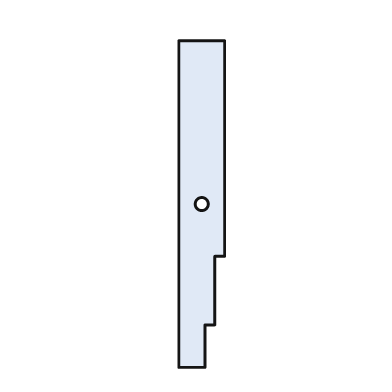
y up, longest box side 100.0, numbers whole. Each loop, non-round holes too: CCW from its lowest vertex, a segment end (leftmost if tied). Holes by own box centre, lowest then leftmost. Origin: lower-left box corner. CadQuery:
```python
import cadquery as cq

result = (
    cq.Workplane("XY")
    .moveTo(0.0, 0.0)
    .lineTo(8.0, 0.0)
    .lineTo(8.0, 13.0)
    .lineTo(11.0, 13.0)
    .lineTo(11.0, 34.0)
    .lineTo(14.0, 34.0)
    .lineTo(14.0, 100.0)
    .lineTo(0.0, 100.0)
    .close()
    .moveTo(7.0, 50.0)
    .circle(2.0)
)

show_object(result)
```